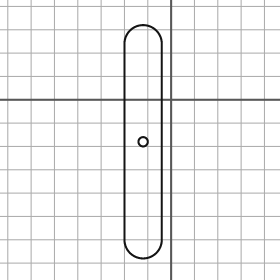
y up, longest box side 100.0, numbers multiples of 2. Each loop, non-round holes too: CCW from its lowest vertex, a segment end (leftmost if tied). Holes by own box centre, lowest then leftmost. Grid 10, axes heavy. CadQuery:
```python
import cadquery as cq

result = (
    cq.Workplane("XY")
    .moveTo(-20.0, -60.0)
    .threePointArc((-12.0, -68.0), (-4.0, -60.0))
    .lineTo(-4.0, 24.0)
    .threePointArc((-12.0, 32.0), (-20.0, 24.0))
    .close()
    .moveTo(-12.0, -18.0)
    .circle(2.0)
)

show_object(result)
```